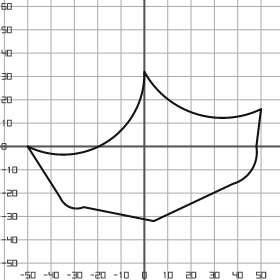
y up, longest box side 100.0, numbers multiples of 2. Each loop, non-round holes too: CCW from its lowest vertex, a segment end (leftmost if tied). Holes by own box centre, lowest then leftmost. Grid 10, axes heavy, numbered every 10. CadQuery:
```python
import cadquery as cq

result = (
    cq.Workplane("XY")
    .moveTo(4.0, -32.0)
    .lineTo(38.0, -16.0)
    .threePointArc((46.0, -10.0), (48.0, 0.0))
    .lineTo(50.0, 16.0)
    .threePointArc((22.0, 14.0), (0.0, 32.0))
    .threePointArc((-16.0, 2.0), (-50.0, 0.0))
    .lineTo(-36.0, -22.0)
    .threePointArc((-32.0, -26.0), (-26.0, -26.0))
    .close()
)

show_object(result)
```